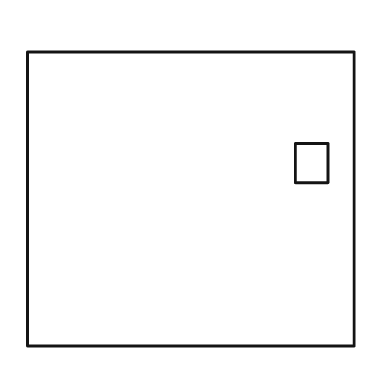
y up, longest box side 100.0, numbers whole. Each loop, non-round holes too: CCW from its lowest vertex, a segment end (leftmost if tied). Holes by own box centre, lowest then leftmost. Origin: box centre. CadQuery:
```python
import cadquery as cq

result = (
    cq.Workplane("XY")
    .moveTo(-50.0, -45.0)
    .lineTo(50.0, -45.0)
    .lineTo(50.0, 45.0)
    .lineTo(-50.0, 45.0)
    .close()
    .moveTo(32.0, 5.0)
    .lineTo(42.0, 5.0)
    .lineTo(42.0, 17.0)
    .lineTo(32.0, 17.0)
    .close()
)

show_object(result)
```